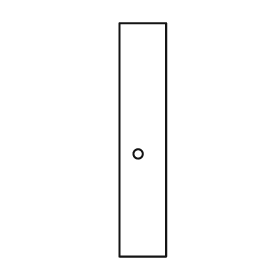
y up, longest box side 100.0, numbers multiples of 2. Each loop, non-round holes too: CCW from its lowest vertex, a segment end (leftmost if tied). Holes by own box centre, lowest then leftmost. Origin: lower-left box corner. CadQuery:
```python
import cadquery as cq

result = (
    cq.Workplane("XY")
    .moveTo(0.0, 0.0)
    .lineTo(20.0, 0.0)
    .lineTo(20.0, 100.0)
    .lineTo(0.0, 100.0)
    .close()
    .moveTo(8.0, 44.0)
    .circle(2.0)
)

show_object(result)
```